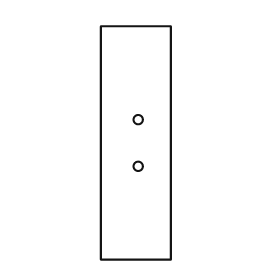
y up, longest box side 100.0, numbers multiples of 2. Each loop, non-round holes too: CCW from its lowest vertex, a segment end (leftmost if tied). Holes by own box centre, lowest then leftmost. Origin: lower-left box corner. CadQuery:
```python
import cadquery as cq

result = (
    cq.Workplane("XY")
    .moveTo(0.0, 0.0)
    .lineTo(30.0, 0.0)
    .lineTo(30.0, 100.0)
    .lineTo(0.0, 100.0)
    .close()
    .moveTo(16.0, 40.0)
    .circle(2.0)
    .moveTo(16.0, 60.0)
    .circle(2.0)
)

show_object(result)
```